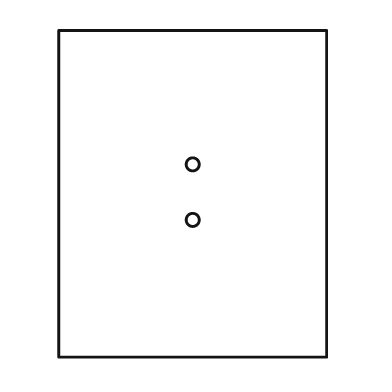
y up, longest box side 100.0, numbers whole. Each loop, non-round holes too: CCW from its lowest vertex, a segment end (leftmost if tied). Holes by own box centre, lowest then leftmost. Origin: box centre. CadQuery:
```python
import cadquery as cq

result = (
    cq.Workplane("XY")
    .moveTo(-41.0, -50.0)
    .lineTo(41.0, -50.0)
    .lineTo(41.0, 50.0)
    .lineTo(-41.0, 50.0)
    .close()
    .moveTo(0.0, -8.0)
    .circle(2.0)
    .moveTo(0.0, 9.0)
    .circle(2.0)
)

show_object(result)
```